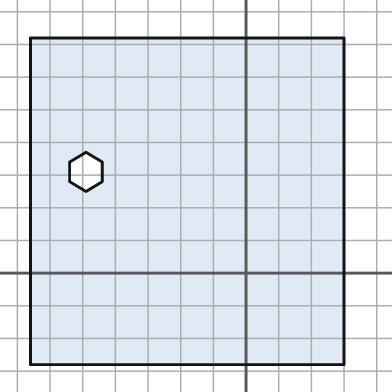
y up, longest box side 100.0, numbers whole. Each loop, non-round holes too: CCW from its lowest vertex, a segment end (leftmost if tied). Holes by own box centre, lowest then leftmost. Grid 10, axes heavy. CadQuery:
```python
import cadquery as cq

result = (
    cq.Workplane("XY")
    .moveTo(-66.0, -28.0)
    .lineTo(30.0, -28.0)
    .lineTo(30.0, 72.0)
    .lineTo(-66.0, 72.0)
    .close()
    .moveTo(-49.0, 25.0)
    .lineTo(-44.0, 28.0)
    .lineTo(-44.0, 34.0)
    .lineTo(-49.0, 37.0)
    .lineTo(-54.0, 34.0)
    .lineTo(-54.0, 28.0)
    .close()
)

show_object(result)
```